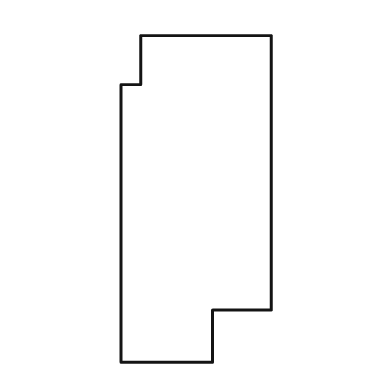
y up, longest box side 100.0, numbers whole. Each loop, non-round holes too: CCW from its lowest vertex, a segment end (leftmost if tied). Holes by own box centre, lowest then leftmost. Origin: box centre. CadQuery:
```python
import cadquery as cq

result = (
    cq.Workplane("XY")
    .moveTo(-23.0, -50.0)
    .lineTo(5.0, -50.0)
    .lineTo(5.0, -34.0)
    .lineTo(23.0, -34.0)
    .lineTo(23.0, 50.0)
    .lineTo(-17.0, 50.0)
    .lineTo(-17.0, 35.0)
    .lineTo(-23.0, 35.0)
    .close()
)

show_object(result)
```